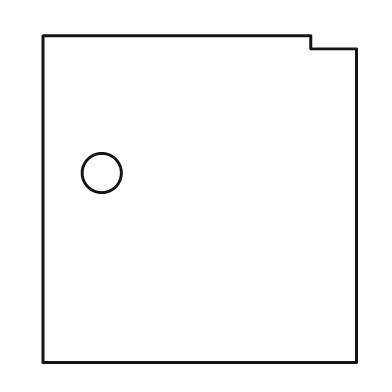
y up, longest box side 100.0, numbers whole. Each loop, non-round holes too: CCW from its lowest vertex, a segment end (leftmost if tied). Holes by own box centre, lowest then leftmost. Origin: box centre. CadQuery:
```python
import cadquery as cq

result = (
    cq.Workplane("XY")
    .moveTo(-48.0, -50.0)
    .lineTo(48.0, -50.0)
    .lineTo(48.0, 46.0)
    .lineTo(34.0, 46.0)
    .lineTo(34.0, 50.0)
    .lineTo(-48.0, 50.0)
    .close()
    .moveTo(-30.0, 8.0)
    .circle(6.0)
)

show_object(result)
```